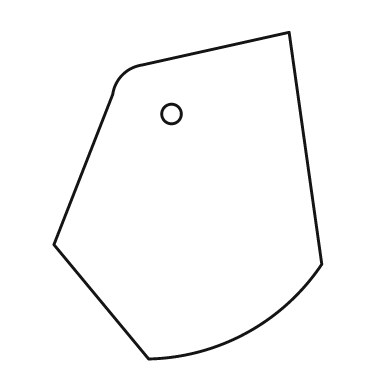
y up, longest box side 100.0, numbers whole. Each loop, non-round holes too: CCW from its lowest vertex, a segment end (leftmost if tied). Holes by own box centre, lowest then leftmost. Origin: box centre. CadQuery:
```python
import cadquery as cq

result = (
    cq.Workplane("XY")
    .moveTo(-12.0, -50.0)
    .threePointArc((18.0, -42.0), (41.0, -21.0))
    .lineTo(31.0, 50.0)
    .lineTo(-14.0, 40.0)
    .threePointArc((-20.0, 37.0), (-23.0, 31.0))
    .lineTo(-41.0, -15.0)
    .close()
    .moveTo(-5.0, 25.0)
    .circle(3.0)
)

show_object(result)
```